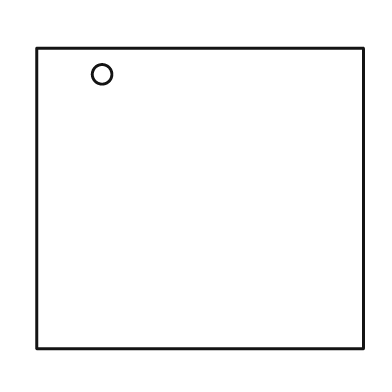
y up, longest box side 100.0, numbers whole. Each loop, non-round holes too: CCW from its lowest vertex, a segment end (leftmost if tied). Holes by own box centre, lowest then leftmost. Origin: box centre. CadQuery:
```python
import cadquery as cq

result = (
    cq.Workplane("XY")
    .moveTo(-50.0, -46.0)
    .lineTo(50.0, -46.0)
    .lineTo(50.0, 46.0)
    .lineTo(-50.0, 46.0)
    .close()
    .moveTo(-30.0, 38.0)
    .circle(3.0)
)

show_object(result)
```